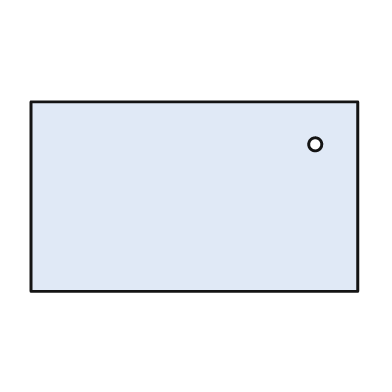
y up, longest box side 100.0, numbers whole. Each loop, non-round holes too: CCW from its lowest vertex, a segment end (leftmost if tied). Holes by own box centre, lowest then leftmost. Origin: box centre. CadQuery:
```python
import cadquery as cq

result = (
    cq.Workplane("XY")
    .moveTo(-50.0, -29.0)
    .lineTo(50.0, -29.0)
    .lineTo(50.0, 29.0)
    .lineTo(-50.0, 29.0)
    .close()
    .moveTo(37.0, 16.0)
    .circle(2.0)
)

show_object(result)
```